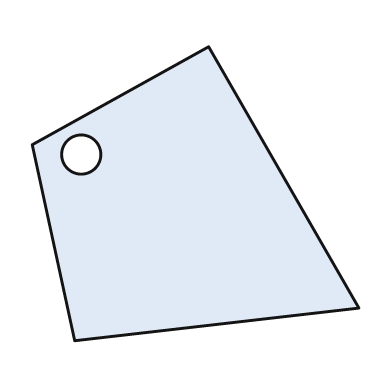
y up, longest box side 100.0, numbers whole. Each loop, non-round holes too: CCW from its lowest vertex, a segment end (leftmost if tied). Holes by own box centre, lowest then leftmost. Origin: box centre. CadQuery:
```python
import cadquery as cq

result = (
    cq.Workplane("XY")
    .moveTo(-37.0, -45.0)
    .lineTo(50.0, -35.0)
    .lineTo(4.0, 45.0)
    .lineTo(-50.0, 15.0)
    .close()
    .moveTo(-35.0, 12.0)
    .circle(6.0)
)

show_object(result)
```